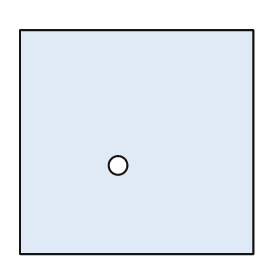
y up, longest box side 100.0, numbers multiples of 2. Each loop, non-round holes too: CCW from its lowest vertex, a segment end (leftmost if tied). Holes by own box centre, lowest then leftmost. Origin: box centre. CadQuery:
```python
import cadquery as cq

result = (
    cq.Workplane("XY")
    .moveTo(-50.0, -48.0)
    .lineTo(50.0, -48.0)
    .lineTo(50.0, 48.0)
    .lineTo(-50.0, 48.0)
    .close()
    .moveTo(-8.0, -10.0)
    .circle(4.0)
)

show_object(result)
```